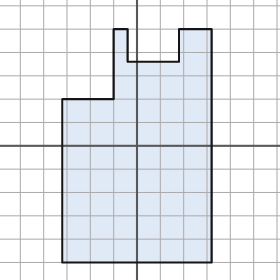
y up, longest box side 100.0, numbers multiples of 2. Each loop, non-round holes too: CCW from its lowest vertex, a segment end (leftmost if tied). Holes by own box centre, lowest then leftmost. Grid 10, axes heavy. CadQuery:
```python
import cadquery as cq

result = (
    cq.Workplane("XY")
    .moveTo(-32.0, -50.0)
    .lineTo(32.0, -50.0)
    .lineTo(32.0, 50.0)
    .lineTo(18.0, 50.0)
    .lineTo(18.0, 36.0)
    .lineTo(-4.0, 36.0)
    .lineTo(-4.0, 50.0)
    .lineTo(-10.0, 50.0)
    .lineTo(-10.0, 20.0)
    .lineTo(-32.0, 20.0)
    .close()
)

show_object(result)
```